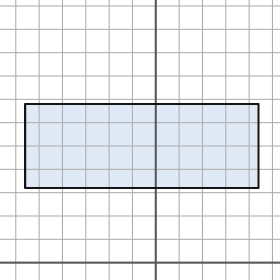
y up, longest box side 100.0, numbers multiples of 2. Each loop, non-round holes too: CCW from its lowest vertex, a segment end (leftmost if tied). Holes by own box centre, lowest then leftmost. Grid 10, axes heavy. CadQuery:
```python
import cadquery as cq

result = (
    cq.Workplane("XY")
    .moveTo(-56.0, 32.0)
    .lineTo(44.0, 32.0)
    .lineTo(44.0, 68.0)
    .lineTo(-56.0, 68.0)
    .close()
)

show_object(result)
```